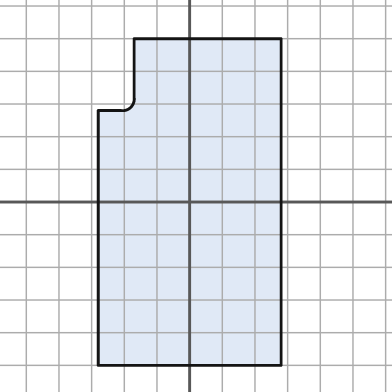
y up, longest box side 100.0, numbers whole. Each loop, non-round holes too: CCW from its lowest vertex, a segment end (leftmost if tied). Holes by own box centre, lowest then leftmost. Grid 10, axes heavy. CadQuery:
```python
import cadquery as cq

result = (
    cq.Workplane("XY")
    .moveTo(-28.0, -50.0)
    .lineTo(28.0, -50.0)
    .lineTo(28.0, 50.0)
    .lineTo(-17.0, 50.0)
    .lineTo(-17.0, 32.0)
    .threePointArc((-18.0, 29.0), (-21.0, 28.0))
    .lineTo(-28.0, 28.0)
    .close()
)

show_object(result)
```